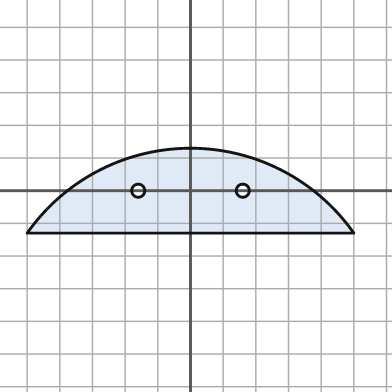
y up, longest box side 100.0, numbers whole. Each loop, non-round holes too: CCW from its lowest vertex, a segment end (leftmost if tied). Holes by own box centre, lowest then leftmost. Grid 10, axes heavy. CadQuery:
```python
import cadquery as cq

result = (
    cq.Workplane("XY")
    .moveTo(-50.0, -13.0)
    .lineTo(50.0, -13.0)
    .threePointArc((0.0, 13.0), (-50.0, -13.0))
    .close()
    .moveTo(-16.0, 0.0)
    .circle(2.0)
    .moveTo(16.0, 0.0)
    .circle(2.0)
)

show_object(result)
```